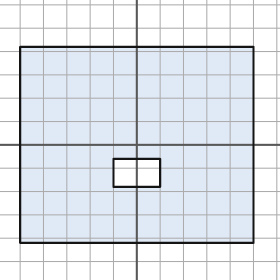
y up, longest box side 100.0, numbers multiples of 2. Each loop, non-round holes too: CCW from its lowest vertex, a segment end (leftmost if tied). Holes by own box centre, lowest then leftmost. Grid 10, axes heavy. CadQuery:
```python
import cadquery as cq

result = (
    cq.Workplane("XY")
    .moveTo(-50.0, -42.0)
    .lineTo(50.0, -42.0)
    .lineTo(50.0, 42.0)
    .lineTo(-50.0, 42.0)
    .close()
    .moveTo(-10.0, -18.0)
    .lineTo(10.0, -18.0)
    .lineTo(10.0, -6.0)
    .lineTo(-10.0, -6.0)
    .close()
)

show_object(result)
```